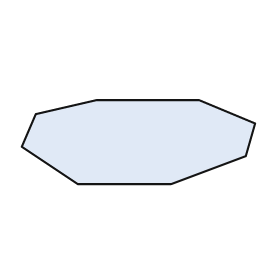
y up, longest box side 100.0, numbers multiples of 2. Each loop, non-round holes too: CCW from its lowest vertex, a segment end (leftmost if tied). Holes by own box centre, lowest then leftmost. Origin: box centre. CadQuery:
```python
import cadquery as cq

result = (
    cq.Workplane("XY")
    .moveTo(-26.0, -18.0)
    .lineTo(14.0, -18.0)
    .lineTo(46.0, -6.0)
    .lineTo(50.0, 8.0)
    .lineTo(26.0, 18.0)
    .lineTo(-18.0, 18.0)
    .lineTo(-44.0, 12.0)
    .lineTo(-50.0, -2.0)
    .close()
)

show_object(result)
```